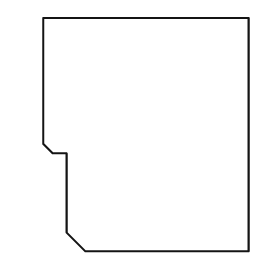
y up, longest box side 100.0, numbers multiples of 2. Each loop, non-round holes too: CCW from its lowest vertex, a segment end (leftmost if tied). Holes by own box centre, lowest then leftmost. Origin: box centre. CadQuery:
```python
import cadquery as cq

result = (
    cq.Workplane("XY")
    .moveTo(-26.0, -50.0)
    .lineTo(44.0, -50.0)
    .lineTo(44.0, 50.0)
    .lineTo(-44.0, 50.0)
    .lineTo(-44.0, -4.0)
    .lineTo(-40.0, -8.0)
    .lineTo(-34.0, -8.0)
    .lineTo(-34.0, -42.0)
    .close()
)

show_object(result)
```